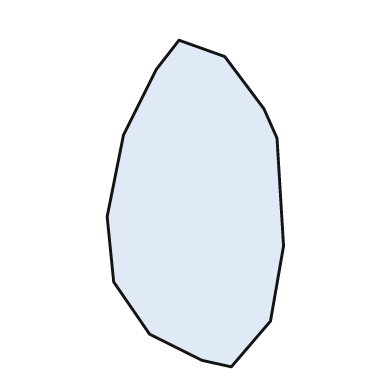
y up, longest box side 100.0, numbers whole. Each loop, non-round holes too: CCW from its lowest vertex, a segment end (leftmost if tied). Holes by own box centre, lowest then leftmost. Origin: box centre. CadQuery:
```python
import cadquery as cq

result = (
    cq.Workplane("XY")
    .moveTo(11.0, -50.0)
    .lineTo(23.0, -36.0)
    .lineTo(27.0, -13.0)
    .lineTo(25.0, 20.0)
    .lineTo(21.0, 29.0)
    .lineTo(9.0, 45.0)
    .lineTo(-5.0, 50.0)
    .lineTo(-12.0, 41.0)
    .lineTo(-22.0, 21.0)
    .lineTo(-27.0, -4.0)
    .lineTo(-25.0, -24.0)
    .lineTo(-14.0, -40.0)
    .lineTo(2.0, -48.0)
    .close()
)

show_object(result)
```